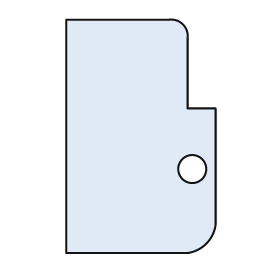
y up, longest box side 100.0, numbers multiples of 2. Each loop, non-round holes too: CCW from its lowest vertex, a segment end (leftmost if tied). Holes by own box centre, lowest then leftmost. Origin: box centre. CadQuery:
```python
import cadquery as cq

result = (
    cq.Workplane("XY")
    .moveTo(-32.0, -50.0)
    .lineTo(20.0, -50.0)
    .threePointArc((28.0, -46.0), (32.0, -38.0))
    .lineTo(32.0, 12.0)
    .lineTo(20.0, 12.0)
    .lineTo(20.0, 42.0)
    .threePointArc((18.0, 48.0), (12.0, 50.0))
    .lineTo(-32.0, 50.0)
    .close()
    .moveTo(22.0, -14.0)
    .circle(6.0)
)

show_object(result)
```